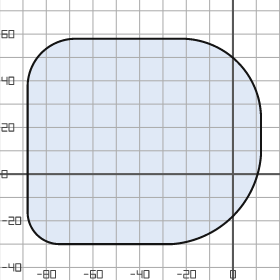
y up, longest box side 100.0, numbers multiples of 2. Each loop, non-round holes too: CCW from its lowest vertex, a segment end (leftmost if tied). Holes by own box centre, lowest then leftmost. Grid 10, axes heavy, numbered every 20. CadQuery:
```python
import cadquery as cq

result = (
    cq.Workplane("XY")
    .moveTo(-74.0, -30.0)
    .lineTo(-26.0, -30.0)
    .threePointArc((0.0, -18.0), (12.0, 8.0))
    .lineTo(12.0, 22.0)
    .threePointArc((2.0, 48.0), (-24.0, 58.0))
    .lineTo(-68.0, 58.0)
    .threePointArc((-82.0, 52.0), (-88.0, 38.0))
    .lineTo(-88.0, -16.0)
    .threePointArc((-84.0, -26.0), (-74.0, -30.0))
    .close()
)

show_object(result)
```